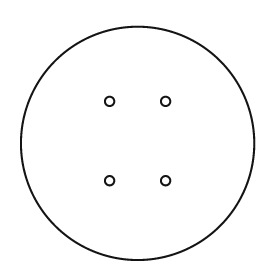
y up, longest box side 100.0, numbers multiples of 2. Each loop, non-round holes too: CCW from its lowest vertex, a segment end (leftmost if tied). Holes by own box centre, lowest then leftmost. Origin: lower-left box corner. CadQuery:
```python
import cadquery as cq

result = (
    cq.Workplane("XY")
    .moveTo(50.0, 50.0)
    .circle(50.0)
    .moveTo(38.0, 34.0)
    .circle(2.0)
    .moveTo(62.0, 34.0)
    .circle(2.0)
    .moveTo(38.0, 68.0)
    .circle(2.0)
    .moveTo(62.0, 68.0)
    .circle(2.0)
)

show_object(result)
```